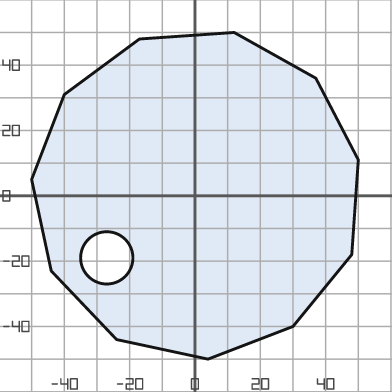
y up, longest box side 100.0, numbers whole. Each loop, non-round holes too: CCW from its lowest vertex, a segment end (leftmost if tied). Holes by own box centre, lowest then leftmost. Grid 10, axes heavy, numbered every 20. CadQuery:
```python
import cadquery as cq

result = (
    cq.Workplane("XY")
    .moveTo(4.0, -50.0)
    .lineTo(30.0, -40.0)
    .lineTo(48.0, -18.0)
    .lineTo(50.0, 11.0)
    .lineTo(37.0, 36.0)
    .lineTo(12.0, 50.0)
    .lineTo(-17.0, 48.0)
    .lineTo(-40.0, 31.0)
    .lineTo(-50.0, 5.0)
    .lineTo(-44.0, -23.0)
    .lineTo(-24.0, -44.0)
    .close()
    .moveTo(-27.0, -19.0)
    .circle(8.0)
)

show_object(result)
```